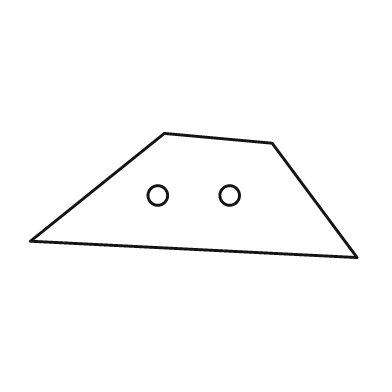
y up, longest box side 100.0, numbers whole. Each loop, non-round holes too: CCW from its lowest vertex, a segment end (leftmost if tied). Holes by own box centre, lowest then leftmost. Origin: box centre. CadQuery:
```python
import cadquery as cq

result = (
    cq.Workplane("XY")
    .moveTo(50.0, -19.0)
    .lineTo(24.0, 16.0)
    .lineTo(-9.0, 19.0)
    .lineTo(-50.0, -14.0)
    .close()
    .moveTo(-11.0, 0.0)
    .circle(3.0)
    .moveTo(11.0, 0.0)
    .circle(3.0)
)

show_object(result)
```